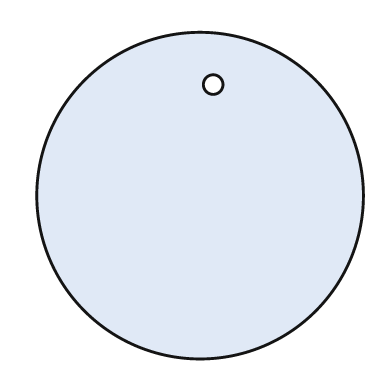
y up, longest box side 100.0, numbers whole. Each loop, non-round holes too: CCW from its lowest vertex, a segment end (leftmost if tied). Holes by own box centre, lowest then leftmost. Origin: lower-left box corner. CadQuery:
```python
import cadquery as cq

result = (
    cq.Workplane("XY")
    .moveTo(50.0, 50.0)
    .circle(50.0)
    .moveTo(54.0, 84.0)
    .circle(3.0)
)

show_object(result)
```